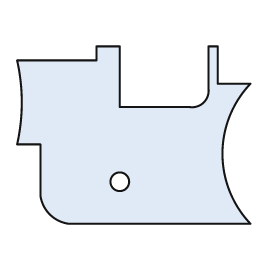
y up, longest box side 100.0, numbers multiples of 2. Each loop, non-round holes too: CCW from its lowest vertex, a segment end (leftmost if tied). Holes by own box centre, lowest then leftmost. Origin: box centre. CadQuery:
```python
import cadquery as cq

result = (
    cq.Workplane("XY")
    .moveTo(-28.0, -38.0)
    .lineTo(50.0, -38.0)
    .threePointArc((38.0, -8.0), (50.0, 22.0))
    .lineTo(36.0, 22.0)
    .lineTo(36.0, 38.0)
    .lineTo(32.0, 38.0)
    .lineTo(32.0, 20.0)
    .threePointArc((30.0, 14.0), (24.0, 12.0))
    .lineTo(-6.0, 12.0)
    .lineTo(-6.0, 38.0)
    .lineTo(-16.0, 38.0)
    .lineTo(-16.0, 32.0)
    .lineTo(-50.0, 32.0)
    .threePointArc((-48.0, 14.0), (-50.0, -4.0))
    .lineTo(-40.0, -4.0)
    .lineTo(-40.0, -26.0)
    .threePointArc((-36.0, -34.0), (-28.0, -38.0))
    .close()
    .moveTo(-6.0, -20.0)
    .circle(4.0)
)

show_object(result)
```